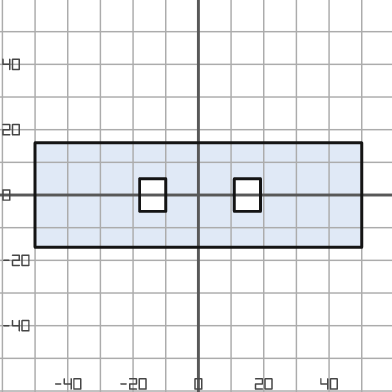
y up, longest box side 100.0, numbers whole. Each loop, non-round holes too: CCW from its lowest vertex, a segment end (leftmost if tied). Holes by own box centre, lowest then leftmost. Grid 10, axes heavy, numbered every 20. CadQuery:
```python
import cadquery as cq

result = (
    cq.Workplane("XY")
    .moveTo(-50.0, -16.0)
    .lineTo(50.0, -16.0)
    .lineTo(50.0, 16.0)
    .lineTo(-50.0, 16.0)
    .close()
    .moveTo(-18.0, -5.0)
    .lineTo(-10.0, -5.0)
    .lineTo(-10.0, 5.0)
    .lineTo(-18.0, 5.0)
    .close()
    .moveTo(11.0, -5.0)
    .lineTo(19.0, -5.0)
    .lineTo(19.0, 5.0)
    .lineTo(11.0, 5.0)
    .close()
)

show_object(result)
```